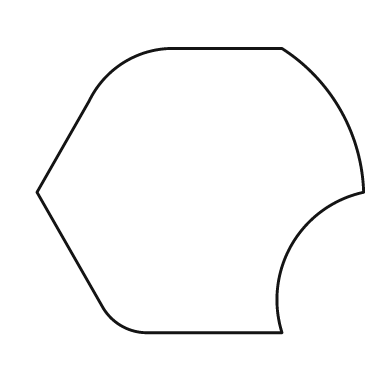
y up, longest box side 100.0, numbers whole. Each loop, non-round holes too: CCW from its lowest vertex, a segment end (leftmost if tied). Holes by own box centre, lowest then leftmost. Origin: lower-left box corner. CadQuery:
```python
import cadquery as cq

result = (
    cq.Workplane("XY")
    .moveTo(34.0, 0.0)
    .lineTo(75.0, 0.0)
    .threePointArc((78.0, 27.0), (100.0, 43.0))
    .threePointArc((93.0, 68.0), (75.0, 87.0))
    .lineTo(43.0, 87.0)
    .threePointArc((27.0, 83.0), (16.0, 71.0))
    .lineTo(0.0, 43.0)
    .lineTo(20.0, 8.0)
    .threePointArc((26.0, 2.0), (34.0, 0.0))
    .close()
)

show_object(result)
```